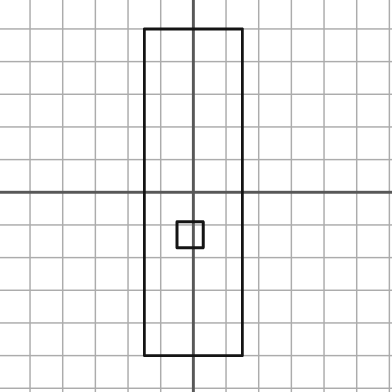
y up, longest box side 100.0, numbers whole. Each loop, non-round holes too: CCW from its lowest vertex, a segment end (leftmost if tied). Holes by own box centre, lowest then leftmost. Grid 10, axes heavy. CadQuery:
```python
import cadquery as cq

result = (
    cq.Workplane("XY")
    .moveTo(-15.0, -50.0)
    .lineTo(15.0, -50.0)
    .lineTo(15.0, 50.0)
    .lineTo(-15.0, 50.0)
    .close()
    .moveTo(-5.0, -17.0)
    .lineTo(3.0, -17.0)
    .lineTo(3.0, -9.0)
    .lineTo(-5.0, -9.0)
    .close()
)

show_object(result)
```